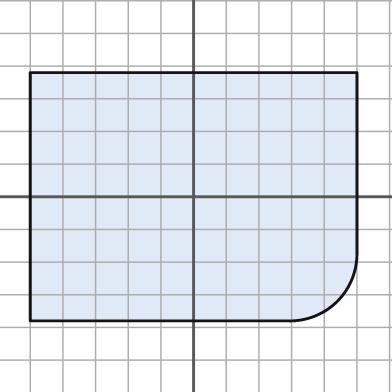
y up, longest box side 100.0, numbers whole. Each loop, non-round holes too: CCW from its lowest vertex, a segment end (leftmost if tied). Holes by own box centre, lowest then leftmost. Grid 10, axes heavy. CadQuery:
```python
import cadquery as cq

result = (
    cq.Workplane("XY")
    .moveTo(-50.0, -38.0)
    .lineTo(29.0, -38.0)
    .threePointArc((44.0, -32.0), (50.0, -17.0))
    .lineTo(50.0, 38.0)
    .lineTo(-50.0, 38.0)
    .close()
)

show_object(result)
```